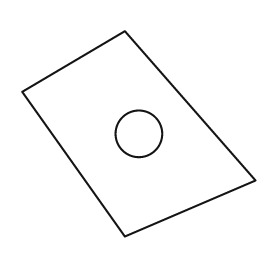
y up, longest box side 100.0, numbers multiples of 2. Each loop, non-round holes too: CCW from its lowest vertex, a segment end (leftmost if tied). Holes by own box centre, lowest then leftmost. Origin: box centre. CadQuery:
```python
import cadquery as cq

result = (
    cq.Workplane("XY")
    .moveTo(-6.0, -44.0)
    .lineTo(50.0, -20.0)
    .lineTo(-6.0, 44.0)
    .lineTo(-50.0, 18.0)
    .close()
    .moveTo(0.0, 0.0)
    .circle(10.0)
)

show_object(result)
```